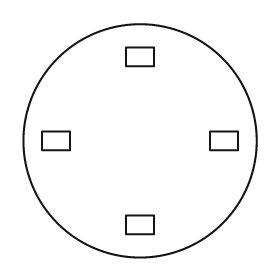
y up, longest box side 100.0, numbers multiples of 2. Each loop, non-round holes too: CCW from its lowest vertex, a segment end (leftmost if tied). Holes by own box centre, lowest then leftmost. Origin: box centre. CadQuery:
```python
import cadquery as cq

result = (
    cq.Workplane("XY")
    .moveTo(0.0, 0.0)
    .circle(50.0)
    .moveTo(-6.0, -40.0)
    .lineTo(6.0, -40.0)
    .lineTo(6.0, -32.0)
    .lineTo(-6.0, -32.0)
    .close()
    .moveTo(-42.0, -4.0)
    .lineTo(-30.0, -4.0)
    .lineTo(-30.0, 4.0)
    .lineTo(-42.0, 4.0)
    .close()
    .moveTo(30.0, -4.0)
    .lineTo(42.0, -4.0)
    .lineTo(42.0, 4.0)
    .lineTo(30.0, 4.0)
    .close()
    .moveTo(-6.0, 32.0)
    .lineTo(6.0, 32.0)
    .lineTo(6.0, 40.0)
    .lineTo(-6.0, 40.0)
    .close()
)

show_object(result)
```